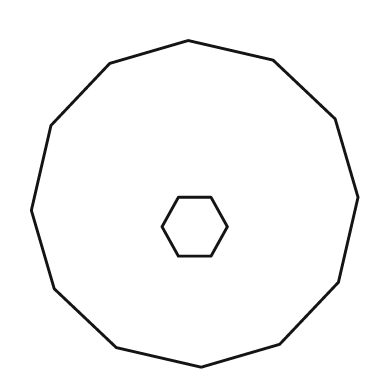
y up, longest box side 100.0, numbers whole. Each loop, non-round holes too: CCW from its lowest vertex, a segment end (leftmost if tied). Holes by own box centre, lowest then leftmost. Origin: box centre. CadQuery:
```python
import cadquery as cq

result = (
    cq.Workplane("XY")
    .moveTo(2.0, -50.0)
    .lineTo(26.0, -43.0)
    .lineTo(44.0, -24.0)
    .lineTo(50.0, 2.0)
    .lineTo(43.0, 26.0)
    .lineTo(24.0, 44.0)
    .lineTo(-2.0, 50.0)
    .lineTo(-26.0, 43.0)
    .lineTo(-44.0, 24.0)
    .lineTo(-50.0, -2.0)
    .lineTo(-43.0, -26.0)
    .lineTo(-24.0, -44.0)
    .close()
    .moveTo(-5.0, -16.0)
    .lineTo(5.0, -16.0)
    .lineTo(10.0, -7.0)
    .lineTo(5.0, 2.0)
    .lineTo(-5.0, 2.0)
    .lineTo(-10.0, -7.0)
    .close()
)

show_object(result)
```